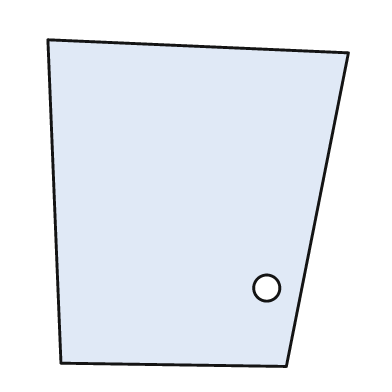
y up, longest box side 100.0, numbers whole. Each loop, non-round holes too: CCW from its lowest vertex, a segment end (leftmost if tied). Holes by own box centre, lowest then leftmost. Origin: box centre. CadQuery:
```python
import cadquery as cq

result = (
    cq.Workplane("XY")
    .moveTo(27.0, -50.0)
    .lineTo(46.0, 46.0)
    .lineTo(-46.0, 50.0)
    .lineTo(-42.0, -49.0)
    .close()
    .moveTo(21.0, -26.0)
    .circle(4.0)
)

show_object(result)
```